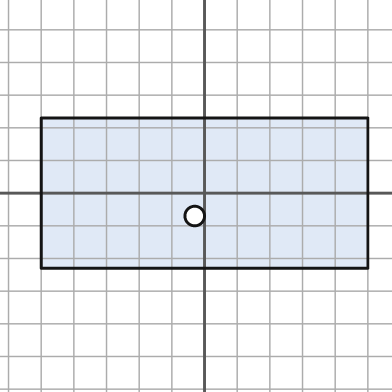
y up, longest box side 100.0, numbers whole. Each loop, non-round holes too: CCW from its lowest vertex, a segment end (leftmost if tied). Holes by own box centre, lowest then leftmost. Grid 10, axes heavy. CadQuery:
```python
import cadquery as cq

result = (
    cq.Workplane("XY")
    .moveTo(-50.0, -23.0)
    .lineTo(50.0, -23.0)
    .lineTo(50.0, 23.0)
    .lineTo(-50.0, 23.0)
    .close()
    .moveTo(-3.0, -7.0)
    .circle(3.0)
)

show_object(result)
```